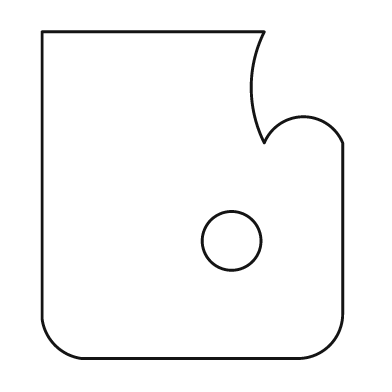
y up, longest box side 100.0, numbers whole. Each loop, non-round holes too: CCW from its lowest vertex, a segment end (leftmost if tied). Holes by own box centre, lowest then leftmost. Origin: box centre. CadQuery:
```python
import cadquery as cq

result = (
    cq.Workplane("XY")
    .moveTo(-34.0, -50.0)
    .lineTo(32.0, -50.0)
    .threePointArc((42.0, -46.0), (46.0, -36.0))
    .lineTo(46.0, 16.0)
    .threePointArc((34.0, 24.0), (22.0, 16.0))
    .threePointArc((18.0, 33.0), (22.0, 50.0))
    .lineTo(-46.0, 50.0)
    .lineTo(-46.0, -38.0)
    .threePointArc((-42.0, -46.0), (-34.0, -50.0))
    .close()
    .moveTo(12.0, -14.0)
    .circle(9.0)
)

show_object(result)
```